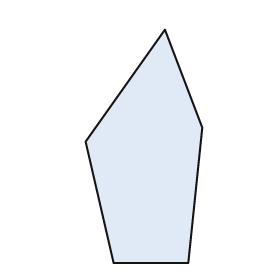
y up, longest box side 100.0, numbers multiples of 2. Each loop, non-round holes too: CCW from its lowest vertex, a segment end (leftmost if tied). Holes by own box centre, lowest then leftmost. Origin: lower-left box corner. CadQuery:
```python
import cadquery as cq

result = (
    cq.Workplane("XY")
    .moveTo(12.0, 0.0)
    .lineTo(44.0, 0.0)
    .lineTo(50.0, 58.0)
    .lineTo(34.0, 100.0)
    .lineTo(0.0, 52.0)
    .close()
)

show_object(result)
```